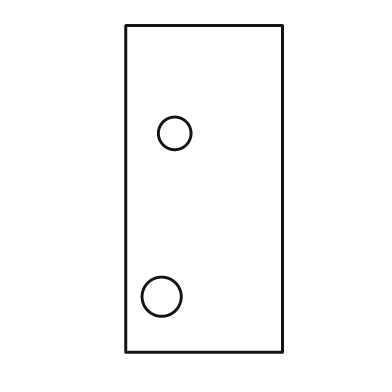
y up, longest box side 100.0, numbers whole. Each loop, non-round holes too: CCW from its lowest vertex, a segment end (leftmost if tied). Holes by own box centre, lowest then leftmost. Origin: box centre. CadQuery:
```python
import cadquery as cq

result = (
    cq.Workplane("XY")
    .moveTo(-24.0, -50.0)
    .lineTo(24.0, -50.0)
    .lineTo(24.0, 50.0)
    .lineTo(-24.0, 50.0)
    .close()
    .moveTo(-13.0, -33.0)
    .circle(6.0)
    .moveTo(-9.0, 17.0)
    .circle(5.0)
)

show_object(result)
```